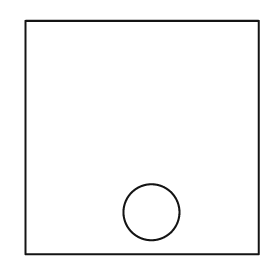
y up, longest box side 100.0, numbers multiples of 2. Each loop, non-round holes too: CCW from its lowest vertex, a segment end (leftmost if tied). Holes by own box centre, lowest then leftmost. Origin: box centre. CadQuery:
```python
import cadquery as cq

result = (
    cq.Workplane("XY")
    .moveTo(-50.0, -50.0)
    .lineTo(50.0, -50.0)
    .lineTo(50.0, 50.0)
    .lineTo(-50.0, 50.0)
    .close()
    .moveTo(4.0, -32.0)
    .circle(12.0)
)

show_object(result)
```